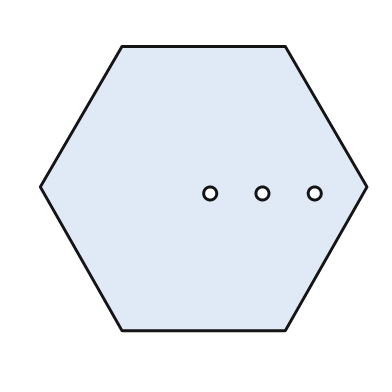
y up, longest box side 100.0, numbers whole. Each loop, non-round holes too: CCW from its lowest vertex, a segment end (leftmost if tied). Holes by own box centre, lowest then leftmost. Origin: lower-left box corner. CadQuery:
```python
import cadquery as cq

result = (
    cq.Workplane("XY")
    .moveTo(25.0, 0.0)
    .lineTo(75.0, 0.0)
    .lineTo(100.0, 44.0)
    .lineTo(75.0, 87.0)
    .lineTo(25.0, 87.0)
    .lineTo(0.0, 44.0)
    .close()
    .moveTo(52.0, 42.0)
    .circle(2.0)
    .moveTo(68.0, 42.0)
    .circle(2.0)
    .moveTo(84.0, 42.0)
    .circle(2.0)
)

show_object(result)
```